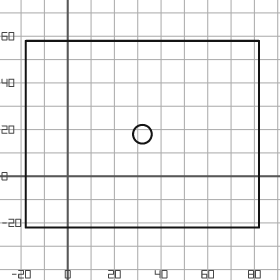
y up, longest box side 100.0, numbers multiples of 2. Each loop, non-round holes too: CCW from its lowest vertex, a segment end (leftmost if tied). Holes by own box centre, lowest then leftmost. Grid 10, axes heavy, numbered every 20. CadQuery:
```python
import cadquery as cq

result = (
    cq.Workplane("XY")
    .moveTo(-18.0, -22.0)
    .lineTo(82.0, -22.0)
    .lineTo(82.0, 58.0)
    .lineTo(-18.0, 58.0)
    .close()
    .moveTo(32.0, 18.0)
    .circle(4.0)
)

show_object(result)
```